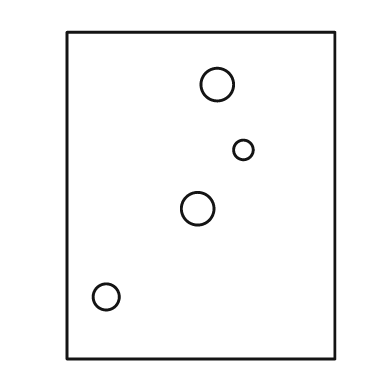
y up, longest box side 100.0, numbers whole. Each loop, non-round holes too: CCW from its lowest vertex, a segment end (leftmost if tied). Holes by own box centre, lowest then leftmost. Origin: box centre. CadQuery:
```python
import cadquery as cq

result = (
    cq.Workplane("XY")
    .moveTo(-41.0, -50.0)
    .lineTo(41.0, -50.0)
    .lineTo(41.0, 50.0)
    .lineTo(-41.0, 50.0)
    .close()
    .moveTo(-29.0, -31.0)
    .circle(4.0)
    .moveTo(-1.0, -4.0)
    .circle(5.0)
    .moveTo(13.0, 14.0)
    .circle(3.0)
    .moveTo(5.0, 34.0)
    .circle(5.0)
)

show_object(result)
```